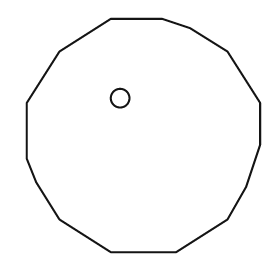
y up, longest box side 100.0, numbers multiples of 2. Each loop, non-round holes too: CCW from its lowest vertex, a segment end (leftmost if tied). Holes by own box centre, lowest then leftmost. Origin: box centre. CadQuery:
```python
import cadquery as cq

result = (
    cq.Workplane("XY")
    .moveTo(-14.0, -50.0)
    .lineTo(14.0, -50.0)
    .lineTo(36.0, -36.0)
    .lineTo(44.0, -22.0)
    .lineTo(50.0, -4.0)
    .lineTo(50.0, 14.0)
    .lineTo(36.0, 36.0)
    .lineTo(20.0, 46.0)
    .lineTo(8.0, 50.0)
    .lineTo(-14.0, 50.0)
    .lineTo(-36.0, 36.0)
    .lineTo(-50.0, 14.0)
    .lineTo(-50.0, -10.0)
    .lineTo(-46.0, -20.0)
    .lineTo(-36.0, -36.0)
    .close()
    .moveTo(-10.0, 16.0)
    .circle(4.0)
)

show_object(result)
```